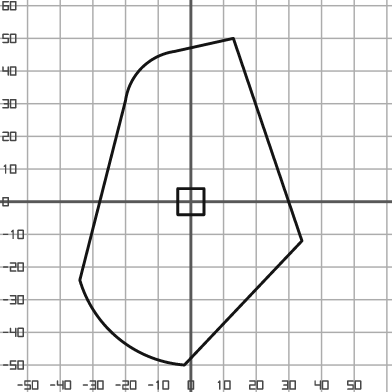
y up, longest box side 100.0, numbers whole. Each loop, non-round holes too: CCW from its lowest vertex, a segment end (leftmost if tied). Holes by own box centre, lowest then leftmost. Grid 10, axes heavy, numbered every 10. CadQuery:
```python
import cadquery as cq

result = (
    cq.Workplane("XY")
    .moveTo(-2.0, -50.0)
    .lineTo(34.0, -12.0)
    .lineTo(13.0, 50.0)
    .lineTo(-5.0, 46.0)
    .threePointArc((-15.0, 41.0), (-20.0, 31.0))
    .lineTo(-34.0, -24.0)
    .threePointArc((-22.0, -42.0), (-2.0, -50.0))
    .close()
    .moveTo(-4.0, -4.0)
    .lineTo(4.0, -4.0)
    .lineTo(4.0, 4.0)
    .lineTo(-4.0, 4.0)
    .close()
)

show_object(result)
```